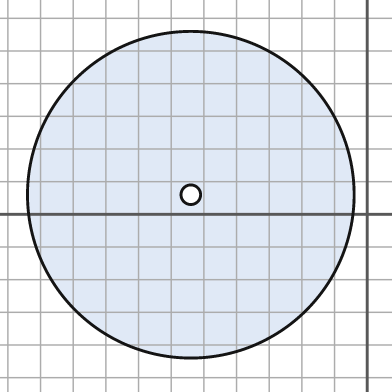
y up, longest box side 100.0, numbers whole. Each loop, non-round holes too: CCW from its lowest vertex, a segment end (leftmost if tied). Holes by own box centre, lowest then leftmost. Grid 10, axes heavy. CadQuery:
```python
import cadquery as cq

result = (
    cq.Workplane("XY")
    .moveTo(-54.0, 6.0)
    .circle(50.0)
    .moveTo(-54.0, 6.0)
    .circle(3.0)
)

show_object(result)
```